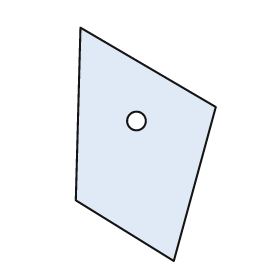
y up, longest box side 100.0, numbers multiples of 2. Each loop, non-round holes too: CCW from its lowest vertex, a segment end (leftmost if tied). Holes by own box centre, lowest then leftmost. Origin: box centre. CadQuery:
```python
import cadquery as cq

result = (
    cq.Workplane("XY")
    .moveTo(12.0, -50.0)
    .lineTo(30.0, 16.0)
    .lineTo(-28.0, 50.0)
    .lineTo(-30.0, -24.0)
    .close()
    .moveTo(-4.0, 10.0)
    .circle(4.0)
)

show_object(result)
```